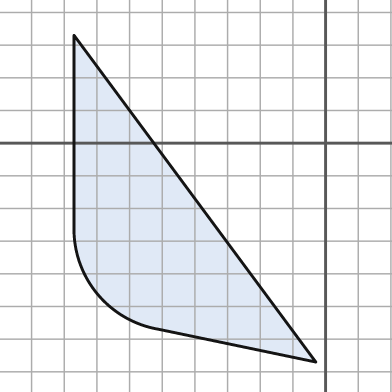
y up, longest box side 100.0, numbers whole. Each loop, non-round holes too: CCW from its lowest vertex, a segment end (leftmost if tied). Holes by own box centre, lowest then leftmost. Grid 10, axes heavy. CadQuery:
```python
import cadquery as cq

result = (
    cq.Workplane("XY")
    .moveTo(-3.0, -67.0)
    .lineTo(-77.0, 33.0)
    .lineTo(-77.0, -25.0)
    .threePointArc((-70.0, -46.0), (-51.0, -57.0))
    .close()
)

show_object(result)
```